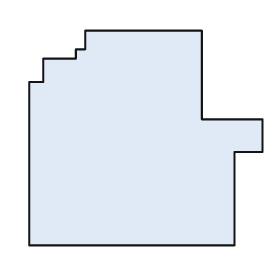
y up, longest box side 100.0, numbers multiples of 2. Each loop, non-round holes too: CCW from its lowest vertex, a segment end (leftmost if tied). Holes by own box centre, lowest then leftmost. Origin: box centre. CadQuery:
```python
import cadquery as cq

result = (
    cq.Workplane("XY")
    .moveTo(-50.0, -46.0)
    .lineTo(38.0, -46.0)
    .lineTo(38.0, -6.0)
    .lineTo(50.0, -6.0)
    .lineTo(50.0, 8.0)
    .lineTo(24.0, 8.0)
    .lineTo(24.0, 46.0)
    .lineTo(-26.0, 46.0)
    .lineTo(-26.0, 38.0)
    .lineTo(-30.0, 38.0)
    .lineTo(-30.0, 34.0)
    .lineTo(-44.0, 34.0)
    .lineTo(-44.0, 24.0)
    .lineTo(-50.0, 24.0)
    .close()
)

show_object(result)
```